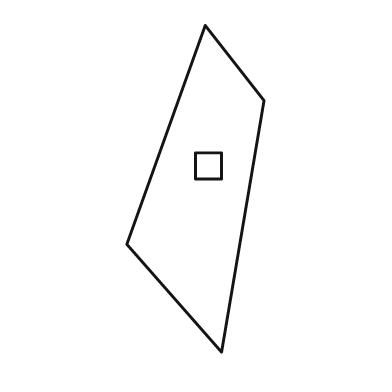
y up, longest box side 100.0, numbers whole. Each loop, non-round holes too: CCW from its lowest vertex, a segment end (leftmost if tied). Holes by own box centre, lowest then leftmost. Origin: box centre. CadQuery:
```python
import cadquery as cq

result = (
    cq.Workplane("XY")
    .moveTo(8.0, -50.0)
    .lineTo(21.0, 27.0)
    .lineTo(3.0, 50.0)
    .lineTo(-21.0, -17.0)
    .close()
    .moveTo(0.0, 3.0)
    .lineTo(8.0, 3.0)
    .lineTo(8.0, 11.0)
    .lineTo(0.0, 11.0)
    .close()
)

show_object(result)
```